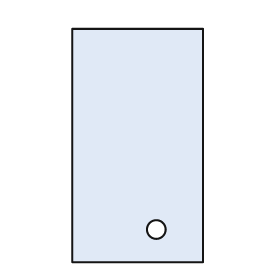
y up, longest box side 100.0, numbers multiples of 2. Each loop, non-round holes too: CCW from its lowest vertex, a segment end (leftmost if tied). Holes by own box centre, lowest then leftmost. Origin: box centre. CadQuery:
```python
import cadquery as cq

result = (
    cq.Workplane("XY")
    .moveTo(-28.0, -50.0)
    .lineTo(28.0, -50.0)
    .lineTo(28.0, 50.0)
    .lineTo(-28.0, 50.0)
    .close()
    .moveTo(8.0, -36.0)
    .circle(4.0)
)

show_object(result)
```